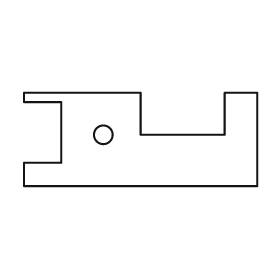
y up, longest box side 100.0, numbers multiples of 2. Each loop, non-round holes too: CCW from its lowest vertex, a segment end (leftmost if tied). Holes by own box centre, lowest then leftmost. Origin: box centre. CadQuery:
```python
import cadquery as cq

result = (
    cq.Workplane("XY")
    .moveTo(-50.0, -20.0)
    .lineTo(50.0, -20.0)
    .lineTo(50.0, 20.0)
    .lineTo(36.0, 20.0)
    .lineTo(36.0, 2.0)
    .lineTo(0.0, 2.0)
    .lineTo(0.0, 20.0)
    .lineTo(-50.0, 20.0)
    .lineTo(-50.0, 16.0)
    .lineTo(-34.0, 16.0)
    .lineTo(-34.0, -10.0)
    .lineTo(-50.0, -10.0)
    .close()
    .moveTo(-16.0, 2.0)
    .circle(4.0)
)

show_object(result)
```